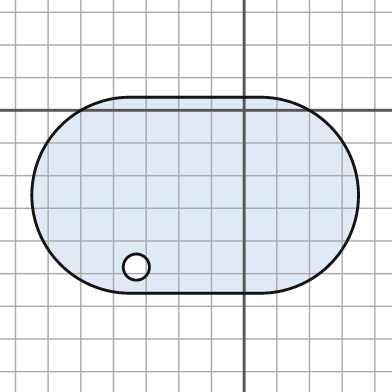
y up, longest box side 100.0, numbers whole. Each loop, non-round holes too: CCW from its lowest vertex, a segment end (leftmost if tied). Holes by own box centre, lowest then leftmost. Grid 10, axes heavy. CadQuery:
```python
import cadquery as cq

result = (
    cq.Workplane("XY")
    .moveTo(-35.0, -56.0)
    .lineTo(5.0, -56.0)
    .threePointArc((35.0, -26.0), (5.0, 4.0))
    .lineTo(-35.0, 4.0)
    .threePointArc((-65.0, -26.0), (-35.0, -56.0))
    .close()
    .moveTo(-33.0, -48.0)
    .circle(4.0)
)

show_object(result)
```